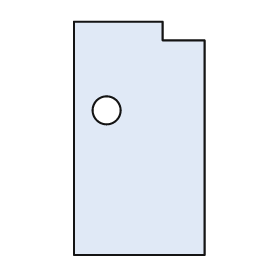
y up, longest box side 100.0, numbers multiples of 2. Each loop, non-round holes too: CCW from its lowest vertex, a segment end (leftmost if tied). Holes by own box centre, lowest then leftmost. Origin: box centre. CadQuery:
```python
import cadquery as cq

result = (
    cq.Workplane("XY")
    .moveTo(-28.0, -50.0)
    .lineTo(28.0, -50.0)
    .lineTo(28.0, 42.0)
    .lineTo(10.0, 42.0)
    .lineTo(10.0, 50.0)
    .lineTo(-28.0, 50.0)
    .close()
    .moveTo(-14.0, 12.0)
    .circle(6.0)
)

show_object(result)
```